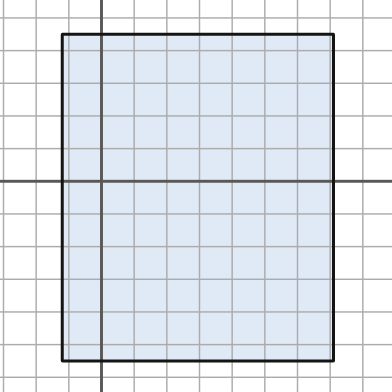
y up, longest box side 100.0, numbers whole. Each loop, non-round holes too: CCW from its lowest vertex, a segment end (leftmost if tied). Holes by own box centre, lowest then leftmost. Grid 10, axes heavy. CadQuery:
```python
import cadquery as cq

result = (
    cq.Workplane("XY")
    .moveTo(-12.0, -55.0)
    .lineTo(71.0, -55.0)
    .lineTo(71.0, 45.0)
    .lineTo(-12.0, 45.0)
    .close()
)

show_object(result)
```